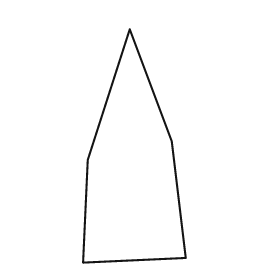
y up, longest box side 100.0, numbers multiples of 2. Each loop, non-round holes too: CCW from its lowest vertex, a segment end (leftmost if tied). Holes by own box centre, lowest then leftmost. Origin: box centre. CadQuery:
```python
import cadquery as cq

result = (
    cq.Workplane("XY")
    .moveTo(-22.0, -50.0)
    .lineTo(22.0, -48.0)
    .lineTo(16.0, 2.0)
    .lineTo(-2.0, 50.0)
    .lineTo(-20.0, -6.0)
    .close()
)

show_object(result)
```